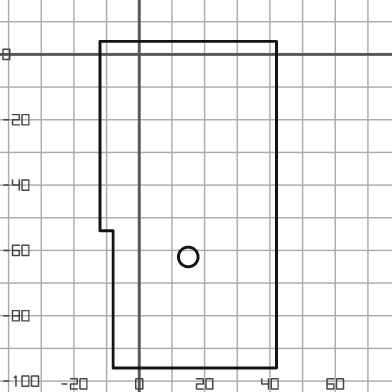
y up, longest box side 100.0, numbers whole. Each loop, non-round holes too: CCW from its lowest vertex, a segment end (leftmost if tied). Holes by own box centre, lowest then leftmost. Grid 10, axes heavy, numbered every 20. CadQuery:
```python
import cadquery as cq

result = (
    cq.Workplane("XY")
    .moveTo(-8.0, -96.0)
    .lineTo(42.0, -96.0)
    .lineTo(42.0, 4.0)
    .lineTo(-12.0, 4.0)
    .lineTo(-12.0, -54.0)
    .lineTo(-8.0, -54.0)
    .close()
    .moveTo(15.0, -62.0)
    .circle(3.0)
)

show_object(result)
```